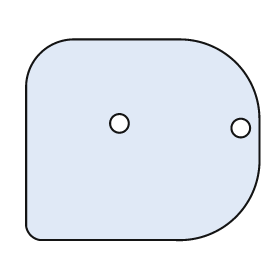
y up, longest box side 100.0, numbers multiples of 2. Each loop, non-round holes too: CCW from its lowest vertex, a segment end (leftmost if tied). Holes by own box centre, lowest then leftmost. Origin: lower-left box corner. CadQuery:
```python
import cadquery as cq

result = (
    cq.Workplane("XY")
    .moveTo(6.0, 0.0)
    .lineTo(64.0, 0.0)
    .threePointArc((90.0, 10.0), (100.0, 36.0))
    .lineTo(100.0, 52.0)
    .threePointArc((90.0, 76.0), (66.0, 86.0))
    .lineTo(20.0, 86.0)
    .threePointArc((6.0, 80.0), (0.0, 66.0))
    .lineTo(0.0, 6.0)
    .threePointArc((2.0, 2.0), (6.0, 0.0))
    .close()
    .moveTo(92.0, 48.0)
    .circle(4.0)
    .moveTo(40.0, 50.0)
    .circle(4.0)
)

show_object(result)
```